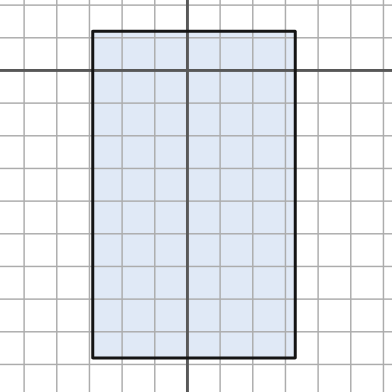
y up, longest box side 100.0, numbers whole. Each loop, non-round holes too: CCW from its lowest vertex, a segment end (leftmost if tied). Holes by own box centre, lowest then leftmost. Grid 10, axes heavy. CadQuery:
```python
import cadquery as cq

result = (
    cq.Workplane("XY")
    .moveTo(-29.0, -88.0)
    .lineTo(33.0, -88.0)
    .lineTo(33.0, 12.0)
    .lineTo(-29.0, 12.0)
    .close()
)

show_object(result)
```